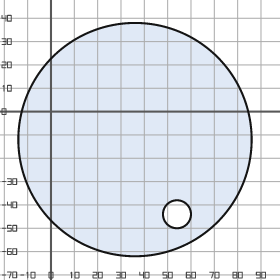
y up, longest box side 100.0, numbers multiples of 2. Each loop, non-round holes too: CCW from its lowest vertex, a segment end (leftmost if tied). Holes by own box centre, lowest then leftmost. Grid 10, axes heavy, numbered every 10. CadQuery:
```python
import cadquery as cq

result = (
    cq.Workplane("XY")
    .moveTo(36.0, -12.0)
    .circle(50.0)
    .moveTo(54.0, -44.0)
    .circle(6.0)
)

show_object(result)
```